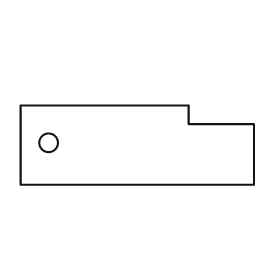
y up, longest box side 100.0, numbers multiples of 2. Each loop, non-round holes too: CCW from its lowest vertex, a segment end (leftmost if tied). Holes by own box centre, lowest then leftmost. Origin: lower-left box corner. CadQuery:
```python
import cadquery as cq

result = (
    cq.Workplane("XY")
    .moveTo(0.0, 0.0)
    .lineTo(100.0, 0.0)
    .lineTo(100.0, 26.0)
    .lineTo(72.0, 26.0)
    .lineTo(72.0, 34.0)
    .lineTo(0.0, 34.0)
    .close()
    .moveTo(12.0, 18.0)
    .circle(4.0)
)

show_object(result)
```